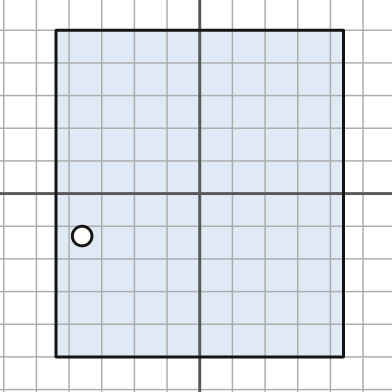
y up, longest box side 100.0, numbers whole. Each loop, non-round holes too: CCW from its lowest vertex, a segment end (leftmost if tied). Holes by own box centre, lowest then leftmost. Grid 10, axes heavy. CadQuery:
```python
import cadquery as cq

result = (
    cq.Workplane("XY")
    .moveTo(-44.0, -50.0)
    .lineTo(44.0, -50.0)
    .lineTo(44.0, 50.0)
    .lineTo(-44.0, 50.0)
    .close()
    .moveTo(-36.0, -13.0)
    .circle(3.0)
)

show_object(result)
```